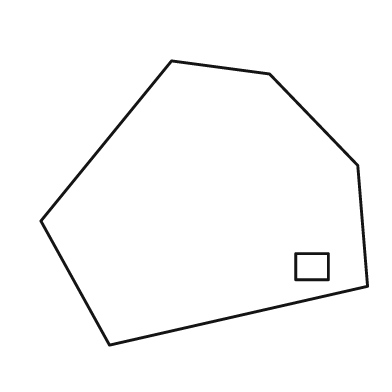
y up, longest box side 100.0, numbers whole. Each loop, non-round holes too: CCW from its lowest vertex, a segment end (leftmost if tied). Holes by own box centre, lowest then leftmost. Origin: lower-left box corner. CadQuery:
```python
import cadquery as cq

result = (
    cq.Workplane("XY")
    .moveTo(21.0, 0.0)
    .lineTo(100.0, 18.0)
    .lineTo(97.0, 55.0)
    .lineTo(70.0, 83.0)
    .lineTo(40.0, 87.0)
    .lineTo(0.0, 38.0)
    .close()
    .moveTo(78.0, 20.0)
    .lineTo(88.0, 20.0)
    .lineTo(88.0, 28.0)
    .lineTo(78.0, 28.0)
    .close()
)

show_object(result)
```